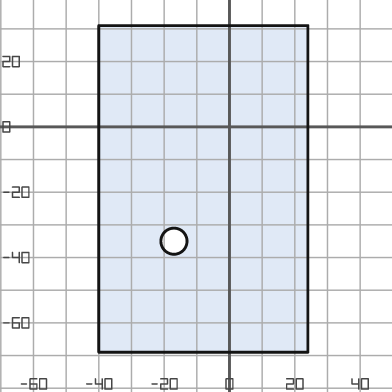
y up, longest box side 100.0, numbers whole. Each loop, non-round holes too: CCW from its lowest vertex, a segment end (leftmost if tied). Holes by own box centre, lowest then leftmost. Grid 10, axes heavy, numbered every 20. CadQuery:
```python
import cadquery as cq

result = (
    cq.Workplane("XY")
    .moveTo(-40.0, -69.0)
    .lineTo(24.0, -69.0)
    .lineTo(24.0, 31.0)
    .lineTo(-40.0, 31.0)
    .close()
    .moveTo(-17.0, -35.0)
    .circle(4.0)
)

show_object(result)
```